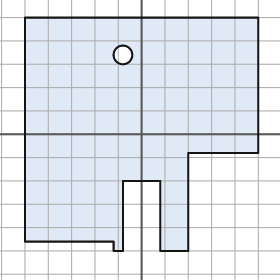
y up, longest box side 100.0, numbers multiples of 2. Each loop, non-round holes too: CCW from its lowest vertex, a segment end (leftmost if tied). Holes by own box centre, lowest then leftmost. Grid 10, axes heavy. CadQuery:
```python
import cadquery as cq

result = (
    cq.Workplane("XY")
    .moveTo(-12.0, -50.0)
    .lineTo(-8.0, -50.0)
    .lineTo(-8.0, -20.0)
    .lineTo(8.0, -20.0)
    .lineTo(8.0, -50.0)
    .lineTo(20.0, -50.0)
    .lineTo(20.0, -8.0)
    .lineTo(50.0, -8.0)
    .lineTo(50.0, 50.0)
    .lineTo(-50.0, 50.0)
    .lineTo(-50.0, -46.0)
    .lineTo(-12.0, -46.0)
    .close()
    .moveTo(-8.0, 34.0)
    .circle(4.0)
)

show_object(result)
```